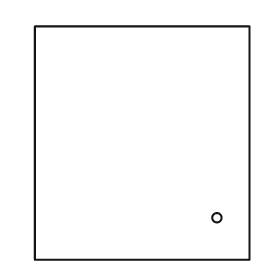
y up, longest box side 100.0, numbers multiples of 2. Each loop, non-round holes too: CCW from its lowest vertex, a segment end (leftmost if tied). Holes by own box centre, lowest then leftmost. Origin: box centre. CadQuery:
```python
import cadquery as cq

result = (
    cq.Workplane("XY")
    .moveTo(-46.0, -50.0)
    .lineTo(46.0, -50.0)
    .lineTo(46.0, 50.0)
    .lineTo(-46.0, 50.0)
    .close()
    .moveTo(32.0, -32.0)
    .circle(2.0)
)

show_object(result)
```